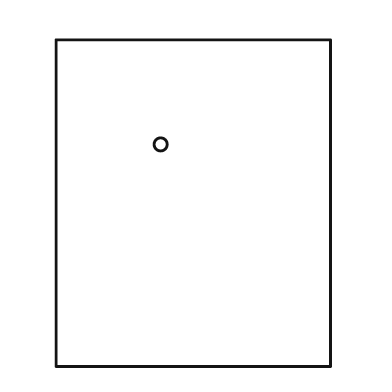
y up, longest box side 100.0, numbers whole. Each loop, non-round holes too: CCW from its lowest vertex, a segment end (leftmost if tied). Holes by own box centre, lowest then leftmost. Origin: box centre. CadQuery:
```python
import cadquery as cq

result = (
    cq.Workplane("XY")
    .moveTo(-42.0, -50.0)
    .lineTo(42.0, -50.0)
    .lineTo(42.0, 50.0)
    .lineTo(-42.0, 50.0)
    .close()
    .moveTo(-10.0, 18.0)
    .circle(2.0)
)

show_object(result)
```